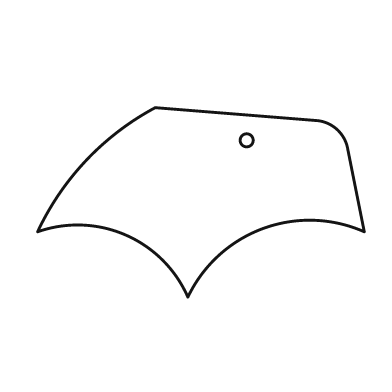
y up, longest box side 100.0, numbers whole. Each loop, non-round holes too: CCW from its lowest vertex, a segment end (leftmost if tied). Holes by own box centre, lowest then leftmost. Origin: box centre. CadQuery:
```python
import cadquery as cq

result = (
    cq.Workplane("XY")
    .moveTo(-4.0, -29.0)
    .threePointArc((19.0, -8.0), (50.0, -9.0))
    .lineTo(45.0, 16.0)
    .threePointArc((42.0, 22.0), (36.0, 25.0))
    .lineTo(-14.0, 29.0)
    .threePointArc((-35.0, 13.0), (-50.0, -9.0))
    .threePointArc((-23.0, -10.0), (-4.0, -29.0))
    .close()
    .moveTo(14.0, 19.0)
    .circle(2.0)
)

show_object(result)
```